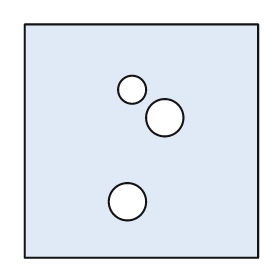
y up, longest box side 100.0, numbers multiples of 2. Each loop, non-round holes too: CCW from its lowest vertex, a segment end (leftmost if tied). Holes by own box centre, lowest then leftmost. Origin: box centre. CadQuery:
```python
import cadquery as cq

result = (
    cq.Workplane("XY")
    .moveTo(-50.0, -50.0)
    .lineTo(50.0, -50.0)
    .lineTo(50.0, 50.0)
    .lineTo(-50.0, 50.0)
    .close()
    .moveTo(-6.0, -26.0)
    .circle(8.0)
    .moveTo(10.0, 10.0)
    .circle(8.0)
    .moveTo(-4.0, 22.0)
    .circle(6.0)
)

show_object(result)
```